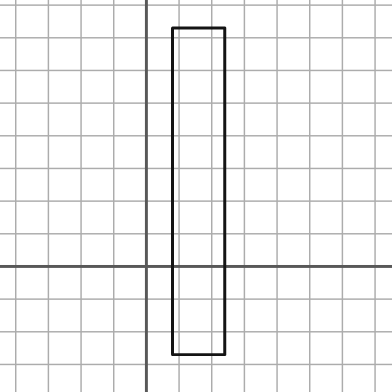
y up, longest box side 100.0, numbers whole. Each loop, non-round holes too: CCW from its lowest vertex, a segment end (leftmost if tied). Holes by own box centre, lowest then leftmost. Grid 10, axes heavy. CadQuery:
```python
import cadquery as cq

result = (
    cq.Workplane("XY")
    .moveTo(8.0, -27.0)
    .lineTo(24.0, -27.0)
    .lineTo(24.0, 73.0)
    .lineTo(8.0, 73.0)
    .close()
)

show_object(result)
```